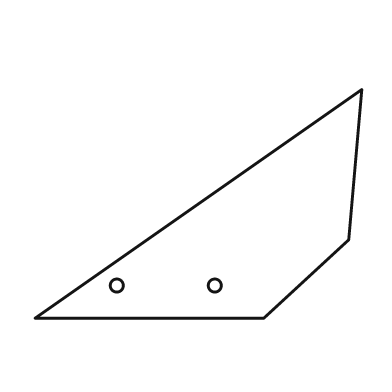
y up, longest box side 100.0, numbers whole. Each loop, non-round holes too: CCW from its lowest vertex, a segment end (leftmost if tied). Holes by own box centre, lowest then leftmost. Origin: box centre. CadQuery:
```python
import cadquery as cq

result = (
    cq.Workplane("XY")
    .moveTo(-50.0, -35.0)
    .lineTo(20.0, -35.0)
    .lineTo(46.0, -11.0)
    .lineTo(50.0, 35.0)
    .close()
    .moveTo(-25.0, -25.0)
    .circle(2.0)
    .moveTo(5.0, -25.0)
    .circle(2.0)
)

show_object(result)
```